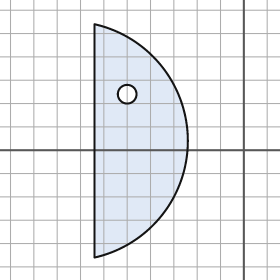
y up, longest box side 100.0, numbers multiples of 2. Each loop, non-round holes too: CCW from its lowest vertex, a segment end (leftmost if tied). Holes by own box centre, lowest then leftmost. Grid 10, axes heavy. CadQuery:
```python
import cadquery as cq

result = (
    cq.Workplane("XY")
    .moveTo(-64.0, -46.0)
    .threePointArc((-24.0, 4.0), (-64.0, 54.0))
    .close()
    .moveTo(-50.0, 24.0)
    .circle(4.0)
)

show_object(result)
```